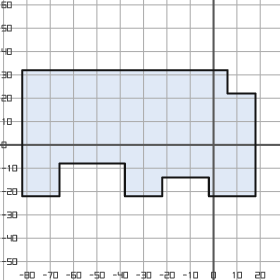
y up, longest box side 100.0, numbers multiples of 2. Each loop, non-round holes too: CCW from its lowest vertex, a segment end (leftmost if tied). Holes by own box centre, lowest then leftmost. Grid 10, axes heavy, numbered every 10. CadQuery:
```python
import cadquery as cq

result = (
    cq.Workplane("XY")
    .moveTo(-82.0, -22.0)
    .lineTo(-66.0, -22.0)
    .lineTo(-66.0, -8.0)
    .lineTo(-38.0, -8.0)
    .lineTo(-38.0, -22.0)
    .lineTo(-22.0, -22.0)
    .lineTo(-22.0, -14.0)
    .lineTo(-2.0, -14.0)
    .lineTo(-2.0, -22.0)
    .lineTo(18.0, -22.0)
    .lineTo(18.0, 22.0)
    .lineTo(6.0, 22.0)
    .lineTo(6.0, 32.0)
    .lineTo(-82.0, 32.0)
    .close()
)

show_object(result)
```